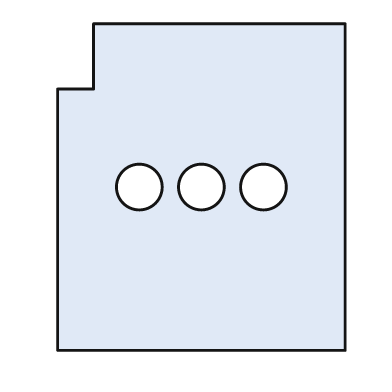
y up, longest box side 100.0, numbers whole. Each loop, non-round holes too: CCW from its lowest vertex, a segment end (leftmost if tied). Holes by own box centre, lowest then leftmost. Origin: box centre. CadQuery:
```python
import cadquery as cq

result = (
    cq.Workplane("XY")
    .moveTo(-44.0, -50.0)
    .lineTo(44.0, -50.0)
    .lineTo(44.0, 50.0)
    .lineTo(-33.0, 50.0)
    .lineTo(-33.0, 30.0)
    .lineTo(-44.0, 30.0)
    .close()
    .moveTo(-19.0, 0.0)
    .circle(7.0)
    .moveTo(0.0, 0.0)
    .circle(7.0)
    .moveTo(19.0, 0.0)
    .circle(7.0)
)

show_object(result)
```